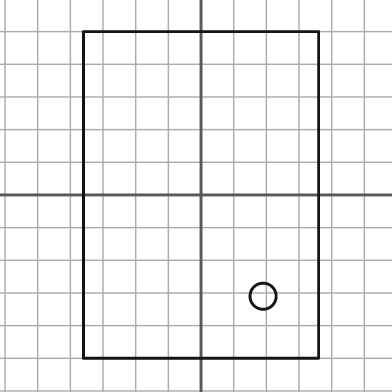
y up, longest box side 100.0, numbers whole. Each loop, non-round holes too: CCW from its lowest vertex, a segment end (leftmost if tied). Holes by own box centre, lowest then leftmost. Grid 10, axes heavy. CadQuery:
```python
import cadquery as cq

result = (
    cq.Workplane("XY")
    .moveTo(-36.0, -50.0)
    .lineTo(36.0, -50.0)
    .lineTo(36.0, 50.0)
    .lineTo(-36.0, 50.0)
    .close()
    .moveTo(19.0, -31.0)
    .circle(4.0)
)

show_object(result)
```